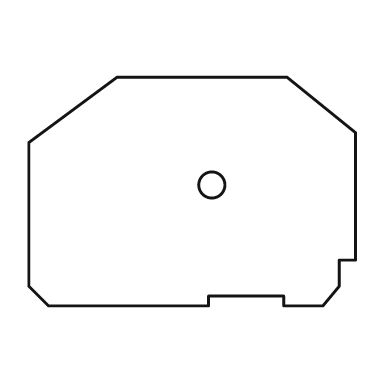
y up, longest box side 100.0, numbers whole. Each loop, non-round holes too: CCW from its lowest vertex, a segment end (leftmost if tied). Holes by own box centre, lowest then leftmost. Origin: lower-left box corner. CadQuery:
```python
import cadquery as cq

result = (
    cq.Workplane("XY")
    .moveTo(6.0, 0.0)
    .lineTo(55.0, 0.0)
    .lineTo(55.0, 3.0)
    .lineTo(78.0, 3.0)
    .lineTo(78.0, 0.0)
    .lineTo(90.0, 0.0)
    .lineTo(95.0, 6.0)
    .lineTo(95.0, 14.0)
    .lineTo(100.0, 14.0)
    .lineTo(100.0, 53.0)
    .lineTo(79.0, 70.0)
    .lineTo(27.0, 70.0)
    .lineTo(0.0, 50.0)
    .lineTo(0.0, 6.0)
    .close()
    .moveTo(56.0, 37.0)
    .circle(4.0)
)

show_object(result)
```